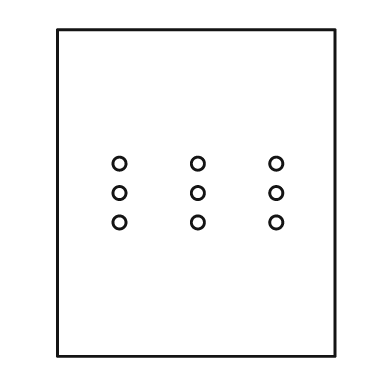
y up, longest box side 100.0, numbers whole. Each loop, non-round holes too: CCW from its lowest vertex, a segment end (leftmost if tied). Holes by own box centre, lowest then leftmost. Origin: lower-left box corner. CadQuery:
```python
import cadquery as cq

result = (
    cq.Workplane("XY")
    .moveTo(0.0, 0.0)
    .lineTo(85.0, 0.0)
    .lineTo(85.0, 100.0)
    .lineTo(0.0, 100.0)
    .close()
    .moveTo(19.0, 41.0)
    .circle(2.0)
    .moveTo(43.0, 41.0)
    .circle(2.0)
    .moveTo(67.0, 41.0)
    .circle(2.0)
    .moveTo(19.0, 50.0)
    .circle(2.0)
    .moveTo(43.0, 50.0)
    .circle(2.0)
    .moveTo(67.0, 50.0)
    .circle(2.0)
    .moveTo(19.0, 59.0)
    .circle(2.0)
    .moveTo(43.0, 59.0)
    .circle(2.0)
    .moveTo(67.0, 59.0)
    .circle(2.0)
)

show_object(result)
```